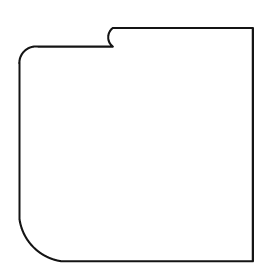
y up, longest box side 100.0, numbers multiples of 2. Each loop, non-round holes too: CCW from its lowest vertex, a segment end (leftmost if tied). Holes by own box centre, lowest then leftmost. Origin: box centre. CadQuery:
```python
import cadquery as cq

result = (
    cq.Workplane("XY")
    .moveTo(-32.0, -50.0)
    .lineTo(50.0, -50.0)
    .lineTo(50.0, 50.0)
    .lineTo(-10.0, 50.0)
    .threePointArc((-12.0, 46.0), (-10.0, 42.0))
    .lineTo(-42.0, 42.0)
    .threePointArc((-48.0, 40.0), (-50.0, 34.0))
    .lineTo(-50.0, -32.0)
    .threePointArc((-44.0, -44.0), (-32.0, -50.0))
    .close()
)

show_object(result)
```